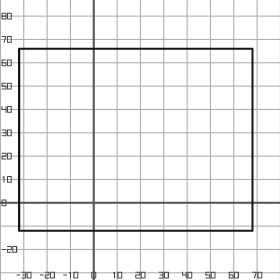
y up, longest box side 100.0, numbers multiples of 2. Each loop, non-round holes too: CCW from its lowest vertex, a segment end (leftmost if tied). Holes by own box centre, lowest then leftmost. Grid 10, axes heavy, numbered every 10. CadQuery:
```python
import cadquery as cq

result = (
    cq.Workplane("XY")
    .moveTo(-32.0, -12.0)
    .lineTo(68.0, -12.0)
    .lineTo(68.0, 66.0)
    .lineTo(-32.0, 66.0)
    .close()
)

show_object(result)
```